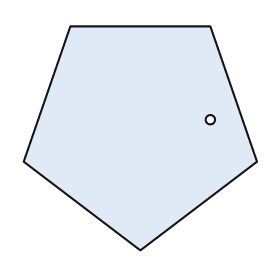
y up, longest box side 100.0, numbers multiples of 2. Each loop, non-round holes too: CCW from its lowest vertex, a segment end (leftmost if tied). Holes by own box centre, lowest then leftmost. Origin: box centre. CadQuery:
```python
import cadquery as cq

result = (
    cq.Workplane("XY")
    .moveTo(0.0, -48.0)
    .lineTo(50.0, -10.0)
    .lineTo(30.0, 48.0)
    .lineTo(-30.0, 48.0)
    .lineTo(-50.0, -10.0)
    .close()
    .moveTo(30.0, 8.0)
    .circle(2.0)
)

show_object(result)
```